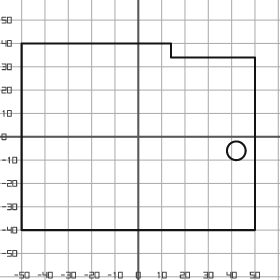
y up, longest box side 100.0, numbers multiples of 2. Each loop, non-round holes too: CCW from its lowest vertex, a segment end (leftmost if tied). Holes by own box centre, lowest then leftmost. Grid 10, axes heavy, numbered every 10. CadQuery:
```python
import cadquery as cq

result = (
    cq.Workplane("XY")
    .moveTo(-50.0, -40.0)
    .lineTo(50.0, -40.0)
    .lineTo(50.0, 34.0)
    .lineTo(14.0, 34.0)
    .lineTo(14.0, 40.0)
    .lineTo(-50.0, 40.0)
    .close()
    .moveTo(42.0, -6.0)
    .circle(4.0)
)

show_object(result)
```